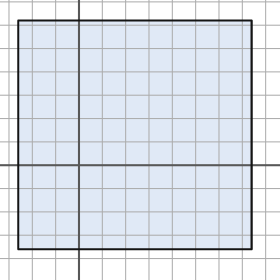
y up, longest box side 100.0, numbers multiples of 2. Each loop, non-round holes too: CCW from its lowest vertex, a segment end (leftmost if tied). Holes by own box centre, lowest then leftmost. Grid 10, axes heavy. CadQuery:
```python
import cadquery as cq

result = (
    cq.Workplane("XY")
    .moveTo(-26.0, -36.0)
    .lineTo(74.0, -36.0)
    .lineTo(74.0, 62.0)
    .lineTo(-26.0, 62.0)
    .close()
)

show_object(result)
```